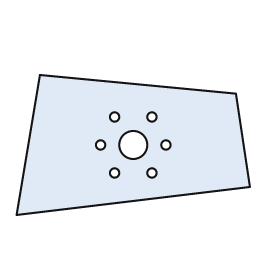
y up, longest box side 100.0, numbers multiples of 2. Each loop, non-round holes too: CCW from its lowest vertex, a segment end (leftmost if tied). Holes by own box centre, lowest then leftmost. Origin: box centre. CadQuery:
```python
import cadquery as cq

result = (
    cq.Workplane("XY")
    .moveTo(-50.0, -30.0)
    .lineTo(50.0, -18.0)
    .lineTo(44.0, 22.0)
    .lineTo(-40.0, 30.0)
    .close()
    .moveTo(-8.0, -12.0)
    .circle(2.0)
    .moveTo(8.0, -12.0)
    .circle(2.0)
    .moveTo(-14.0, 0.0)
    .circle(2.0)
    .moveTo(0.0, 0.0)
    .circle(6.0)
    .moveTo(14.0, 0.0)
    .circle(2.0)
    .moveTo(-8.0, 12.0)
    .circle(2.0)
    .moveTo(8.0, 12.0)
    .circle(2.0)
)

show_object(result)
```